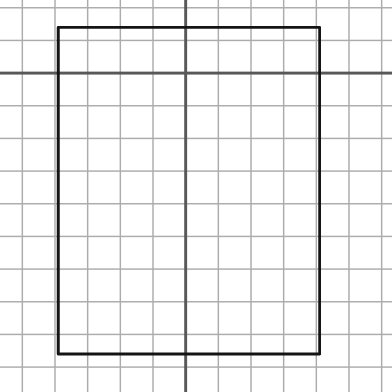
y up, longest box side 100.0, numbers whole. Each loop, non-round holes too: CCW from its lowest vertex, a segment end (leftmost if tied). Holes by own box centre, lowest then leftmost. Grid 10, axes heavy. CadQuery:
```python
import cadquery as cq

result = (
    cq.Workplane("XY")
    .moveTo(-39.0, -86.0)
    .lineTo(41.0, -86.0)
    .lineTo(41.0, 14.0)
    .lineTo(-39.0, 14.0)
    .close()
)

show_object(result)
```